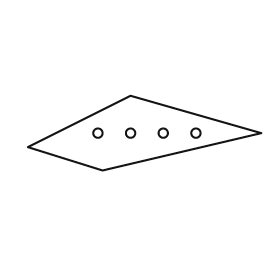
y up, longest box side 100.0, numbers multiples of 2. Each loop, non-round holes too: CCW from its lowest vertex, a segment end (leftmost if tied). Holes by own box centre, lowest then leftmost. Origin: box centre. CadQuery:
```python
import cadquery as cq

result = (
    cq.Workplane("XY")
    .moveTo(-18.0, -16.0)
    .lineTo(50.0, 0.0)
    .lineTo(-6.0, 16.0)
    .lineTo(-50.0, -6.0)
    .close()
    .moveTo(-20.0, 0.0)
    .circle(2.0)
    .moveTo(-6.0, 0.0)
    .circle(2.0)
    .moveTo(8.0, 0.0)
    .circle(2.0)
    .moveTo(22.0, 0.0)
    .circle(2.0)
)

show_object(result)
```